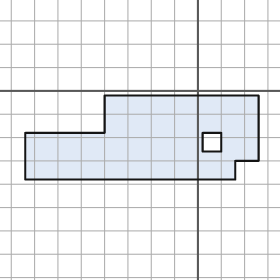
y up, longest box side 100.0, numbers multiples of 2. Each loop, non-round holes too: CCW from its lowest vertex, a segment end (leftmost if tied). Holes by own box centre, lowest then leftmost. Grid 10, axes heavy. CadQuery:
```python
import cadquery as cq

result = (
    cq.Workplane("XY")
    .moveTo(-74.0, -38.0)
    .lineTo(16.0, -38.0)
    .lineTo(16.0, -30.0)
    .lineTo(26.0, -30.0)
    .lineTo(26.0, -2.0)
    .lineTo(-40.0, -2.0)
    .lineTo(-40.0, -18.0)
    .lineTo(-74.0, -18.0)
    .close()
    .moveTo(2.0, -26.0)
    .lineTo(10.0, -26.0)
    .lineTo(10.0, -18.0)
    .lineTo(2.0, -18.0)
    .close()
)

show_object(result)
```